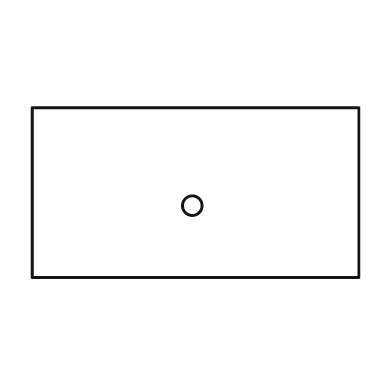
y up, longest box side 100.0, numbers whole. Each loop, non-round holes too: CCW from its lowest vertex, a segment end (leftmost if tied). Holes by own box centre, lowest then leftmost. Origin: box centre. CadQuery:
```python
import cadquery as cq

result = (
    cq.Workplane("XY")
    .moveTo(-50.0, -26.0)
    .lineTo(50.0, -26.0)
    .lineTo(50.0, 26.0)
    .lineTo(-50.0, 26.0)
    .close()
    .moveTo(-1.0, -4.0)
    .circle(3.0)
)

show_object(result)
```